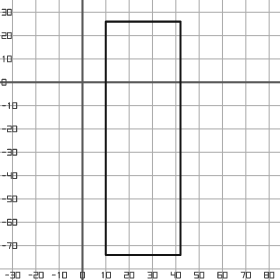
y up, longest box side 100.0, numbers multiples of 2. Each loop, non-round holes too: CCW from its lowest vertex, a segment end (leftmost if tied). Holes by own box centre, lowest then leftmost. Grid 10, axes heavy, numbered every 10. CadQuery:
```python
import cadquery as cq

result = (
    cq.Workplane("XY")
    .moveTo(10.0, -74.0)
    .lineTo(42.0, -74.0)
    .lineTo(42.0, 26.0)
    .lineTo(10.0, 26.0)
    .close()
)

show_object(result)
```